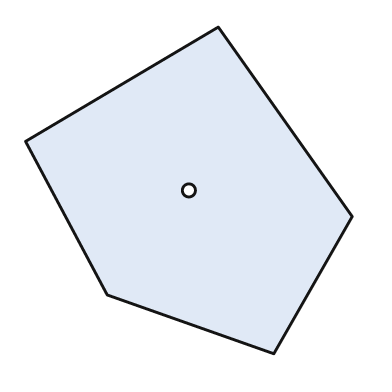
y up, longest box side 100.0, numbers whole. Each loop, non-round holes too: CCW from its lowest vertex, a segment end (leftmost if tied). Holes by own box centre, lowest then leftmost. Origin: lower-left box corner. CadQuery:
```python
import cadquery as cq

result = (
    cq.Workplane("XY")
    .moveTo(76.0, 0.0)
    .lineTo(100.0, 42.0)
    .lineTo(59.0, 100.0)
    .lineTo(0.0, 65.0)
    .lineTo(25.0, 18.0)
    .close()
    .moveTo(50.0, 50.0)
    .circle(2.0)
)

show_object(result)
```